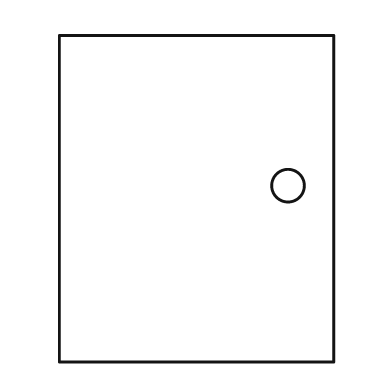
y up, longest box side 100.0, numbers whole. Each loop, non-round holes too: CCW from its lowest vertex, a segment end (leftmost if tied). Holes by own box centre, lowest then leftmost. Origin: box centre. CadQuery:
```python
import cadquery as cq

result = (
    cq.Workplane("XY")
    .moveTo(-42.0, -50.0)
    .lineTo(42.0, -50.0)
    .lineTo(42.0, 50.0)
    .lineTo(-42.0, 50.0)
    .close()
    .moveTo(28.0, 4.0)
    .circle(5.0)
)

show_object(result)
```